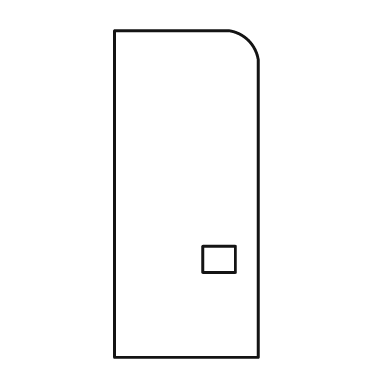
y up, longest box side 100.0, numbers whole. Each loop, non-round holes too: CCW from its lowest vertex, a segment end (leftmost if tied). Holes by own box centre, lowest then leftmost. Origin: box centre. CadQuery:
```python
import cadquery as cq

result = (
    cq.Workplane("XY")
    .moveTo(-22.0, -50.0)
    .lineTo(22.0, -50.0)
    .lineTo(22.0, 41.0)
    .threePointArc((19.0, 47.0), (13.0, 50.0))
    .lineTo(-22.0, 50.0)
    .close()
    .moveTo(5.0, -24.0)
    .lineTo(15.0, -24.0)
    .lineTo(15.0, -16.0)
    .lineTo(5.0, -16.0)
    .close()
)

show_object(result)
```